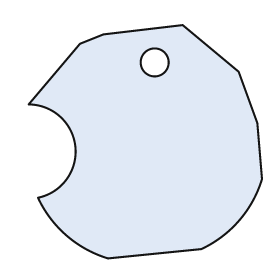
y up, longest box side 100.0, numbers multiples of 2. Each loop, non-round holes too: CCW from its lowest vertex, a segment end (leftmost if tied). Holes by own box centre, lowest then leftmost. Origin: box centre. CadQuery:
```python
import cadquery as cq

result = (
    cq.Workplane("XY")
    .moveTo(-16.0, -50.0)
    .lineTo(24.0, -46.0)
    .threePointArc((40.0, -34.0), (50.0, -16.0))
    .lineTo(48.0, 8.0)
    .lineTo(40.0, 30.0)
    .lineTo(16.0, 50.0)
    .lineTo(-18.0, 46.0)
    .lineTo(-28.0, 42.0)
    .lineTo(-50.0, 16.0)
    .threePointArc((-30.0, -2.0), (-46.0, -24.0))
    .threePointArc((-34.0, -40.0), (-16.0, -50.0))
    .close()
    .moveTo(4.0, 34.0)
    .circle(6.0)
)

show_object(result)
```